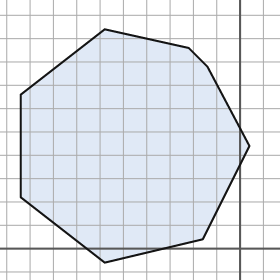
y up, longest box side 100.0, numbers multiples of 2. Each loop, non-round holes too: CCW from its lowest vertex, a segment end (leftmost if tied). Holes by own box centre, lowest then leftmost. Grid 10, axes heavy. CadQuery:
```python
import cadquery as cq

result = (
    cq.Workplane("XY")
    .moveTo(-58.0, -6.0)
    .lineTo(-16.0, 4.0)
    .lineTo(4.0, 44.0)
    .lineTo(-14.0, 78.0)
    .lineTo(-22.0, 86.0)
    .lineTo(-58.0, 94.0)
    .lineTo(-94.0, 66.0)
    .lineTo(-94.0, 22.0)
    .close()
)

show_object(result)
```